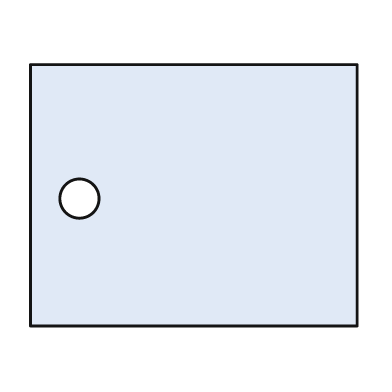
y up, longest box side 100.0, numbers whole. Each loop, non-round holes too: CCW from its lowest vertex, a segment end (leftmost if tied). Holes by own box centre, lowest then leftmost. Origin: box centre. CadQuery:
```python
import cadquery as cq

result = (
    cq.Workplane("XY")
    .moveTo(-50.0, -40.0)
    .lineTo(50.0, -40.0)
    .lineTo(50.0, 40.0)
    .lineTo(-50.0, 40.0)
    .close()
    .moveTo(-35.0, -1.0)
    .circle(6.0)
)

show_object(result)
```